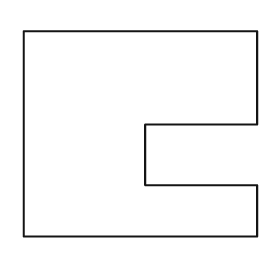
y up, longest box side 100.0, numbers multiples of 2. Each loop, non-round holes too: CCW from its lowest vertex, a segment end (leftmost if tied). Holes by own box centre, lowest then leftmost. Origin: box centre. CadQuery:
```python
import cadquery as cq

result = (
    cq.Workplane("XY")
    .moveTo(-50.0, -44.0)
    .lineTo(50.0, -44.0)
    .lineTo(50.0, -22.0)
    .lineTo(2.0, -22.0)
    .lineTo(2.0, 4.0)
    .lineTo(50.0, 4.0)
    .lineTo(50.0, 44.0)
    .lineTo(-50.0, 44.0)
    .close()
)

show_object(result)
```